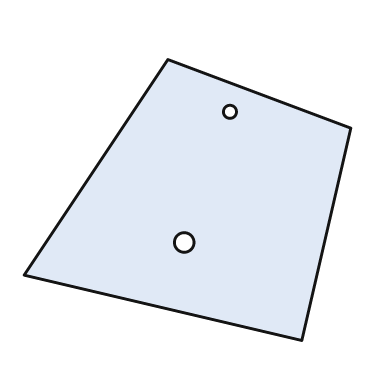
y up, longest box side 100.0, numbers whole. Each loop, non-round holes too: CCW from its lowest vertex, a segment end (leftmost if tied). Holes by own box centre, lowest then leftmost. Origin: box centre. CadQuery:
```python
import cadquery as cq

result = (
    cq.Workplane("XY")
    .moveTo(35.0, -43.0)
    .lineTo(50.0, 22.0)
    .lineTo(-6.0, 43.0)
    .lineTo(-50.0, -23.0)
    .close()
    .moveTo(-1.0, -13.0)
    .circle(3.0)
    .moveTo(13.0, 27.0)
    .circle(2.0)
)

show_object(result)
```